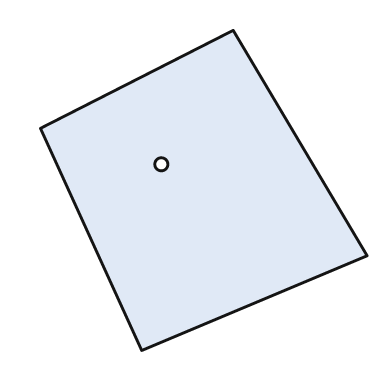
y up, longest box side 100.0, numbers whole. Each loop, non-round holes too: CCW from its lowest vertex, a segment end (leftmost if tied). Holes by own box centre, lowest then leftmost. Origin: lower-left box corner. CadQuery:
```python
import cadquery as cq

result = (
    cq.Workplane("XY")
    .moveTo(31.0, 0.0)
    .lineTo(100.0, 29.0)
    .lineTo(59.0, 98.0)
    .lineTo(0.0, 68.0)
    .close()
    .moveTo(37.0, 57.0)
    .circle(2.0)
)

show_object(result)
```